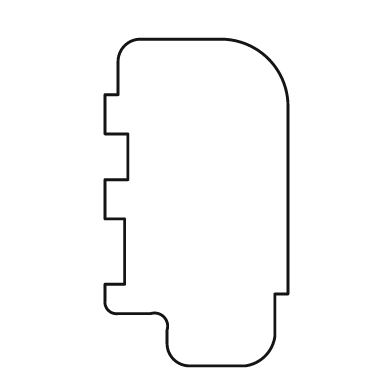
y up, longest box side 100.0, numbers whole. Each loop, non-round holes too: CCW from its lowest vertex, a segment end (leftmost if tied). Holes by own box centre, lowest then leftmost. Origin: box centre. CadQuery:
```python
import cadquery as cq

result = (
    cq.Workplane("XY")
    .moveTo(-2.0, -50.0)
    .lineTo(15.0, -50.0)
    .threePointArc((21.0, -47.0), (24.0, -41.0))
    .lineTo(24.0, -28.0)
    .lineTo(28.0, -28.0)
    .lineTo(28.0, 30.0)
    .threePointArc((22.0, 44.0), (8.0, 50.0))
    .lineTo(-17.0, 50.0)
    .threePointArc((-22.0, 48.0), (-24.0, 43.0))
    .lineTo(-24.0, 33.0)
    .lineTo(-28.0, 33.0)
    .lineTo(-28.0, 21.0)
    .lineTo(-21.0, 21.0)
    .lineTo(-21.0, 7.0)
    .lineTo(-28.0, 7.0)
    .lineTo(-28.0, -5.0)
    .lineTo(-22.0, -5.0)
    .lineTo(-22.0, -25.0)
    .lineTo(-28.0, -25.0)
    .lineTo(-28.0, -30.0)
    .threePointArc((-27.0, -33.0), (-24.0, -34.0))
    .lineTo(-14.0, -34.0)
    .threePointArc((-10.0, -35.0), (-9.0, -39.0))
    .lineTo(-9.0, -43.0)
    .threePointArc((-7.0, -48.0), (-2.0, -50.0))
    .close()
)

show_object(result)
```